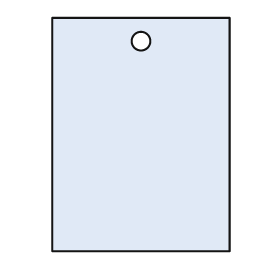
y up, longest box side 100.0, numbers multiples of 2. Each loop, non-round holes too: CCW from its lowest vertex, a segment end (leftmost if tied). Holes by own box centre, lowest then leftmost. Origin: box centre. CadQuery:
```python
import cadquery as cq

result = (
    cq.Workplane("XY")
    .moveTo(-38.0, -50.0)
    .lineTo(38.0, -50.0)
    .lineTo(38.0, 50.0)
    .lineTo(-38.0, 50.0)
    .close()
    .moveTo(0.0, 40.0)
    .circle(4.0)
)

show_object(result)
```